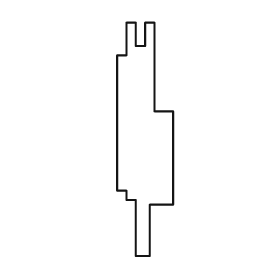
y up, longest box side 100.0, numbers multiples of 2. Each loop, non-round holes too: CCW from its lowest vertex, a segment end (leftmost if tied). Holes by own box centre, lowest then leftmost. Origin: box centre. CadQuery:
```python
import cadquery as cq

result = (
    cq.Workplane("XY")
    .moveTo(-4.0, -50.0)
    .lineTo(2.0, -50.0)
    .lineTo(2.0, -28.0)
    .lineTo(12.0, -28.0)
    .lineTo(12.0, 12.0)
    .lineTo(4.0, 12.0)
    .lineTo(4.0, 50.0)
    .lineTo(0.0, 50.0)
    .lineTo(0.0, 40.0)
    .lineTo(-4.0, 40.0)
    .lineTo(-4.0, 50.0)
    .lineTo(-8.0, 50.0)
    .lineTo(-8.0, 36.0)
    .lineTo(-12.0, 36.0)
    .lineTo(-12.0, -22.0)
    .lineTo(-8.0, -22.0)
    .lineTo(-8.0, -26.0)
    .lineTo(-4.0, -26.0)
    .close()
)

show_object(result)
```